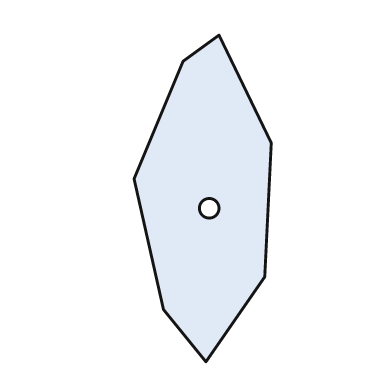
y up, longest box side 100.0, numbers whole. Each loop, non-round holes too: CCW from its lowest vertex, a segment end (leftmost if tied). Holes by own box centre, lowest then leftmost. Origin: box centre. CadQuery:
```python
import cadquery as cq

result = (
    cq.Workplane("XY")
    .moveTo(1.0, -50.0)
    .lineTo(19.0, -24.0)
    .lineTo(21.0, 17.0)
    .lineTo(5.0, 50.0)
    .lineTo(-6.0, 42.0)
    .lineTo(-21.0, 6.0)
    .lineTo(-12.0, -34.0)
    .close()
    .moveTo(2.0, -3.0)
    .circle(3.0)
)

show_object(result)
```